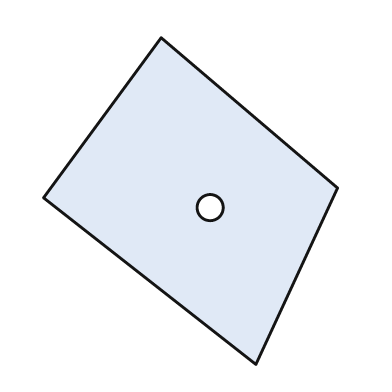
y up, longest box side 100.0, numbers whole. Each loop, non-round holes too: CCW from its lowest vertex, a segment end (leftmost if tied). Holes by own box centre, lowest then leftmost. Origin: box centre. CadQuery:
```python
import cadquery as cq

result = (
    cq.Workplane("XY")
    .moveTo(20.0, -50.0)
    .lineTo(45.0, 4.0)
    .lineTo(-9.0, 50.0)
    .lineTo(-45.0, 1.0)
    .close()
    .moveTo(6.0, -2.0)
    .circle(4.0)
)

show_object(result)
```